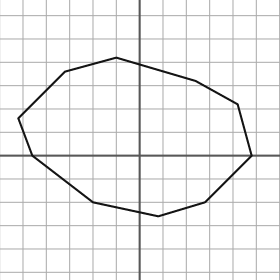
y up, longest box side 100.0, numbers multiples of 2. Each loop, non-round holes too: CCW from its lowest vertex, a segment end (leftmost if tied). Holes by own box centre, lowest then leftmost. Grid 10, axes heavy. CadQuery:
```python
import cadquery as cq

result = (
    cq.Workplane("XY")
    .moveTo(8.0, -26.0)
    .lineTo(28.0, -20.0)
    .lineTo(48.0, 0.0)
    .lineTo(42.0, 22.0)
    .lineTo(24.0, 32.0)
    .lineTo(-10.0, 42.0)
    .lineTo(-32.0, 36.0)
    .lineTo(-52.0, 16.0)
    .lineTo(-46.0, 0.0)
    .lineTo(-20.0, -20.0)
    .close()
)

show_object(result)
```